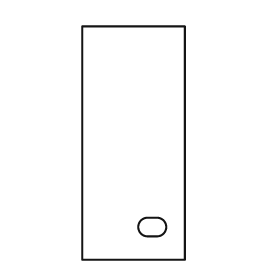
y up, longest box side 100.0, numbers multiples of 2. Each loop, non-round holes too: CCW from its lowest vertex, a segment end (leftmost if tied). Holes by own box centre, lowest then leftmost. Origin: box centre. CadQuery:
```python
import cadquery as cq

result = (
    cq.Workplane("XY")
    .moveTo(-22.0, -50.0)
    .lineTo(22.0, -50.0)
    .lineTo(22.0, 50.0)
    .lineTo(-22.0, 50.0)
    .close()
    .moveTo(6.0, -40.0)
    .lineTo(10.0, -40.0)
    .threePointArc((14.0, -36.0), (10.0, -32.0))
    .lineTo(6.0, -32.0)
    .threePointArc((2.0, -36.0), (6.0, -40.0))
    .close()
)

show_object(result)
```